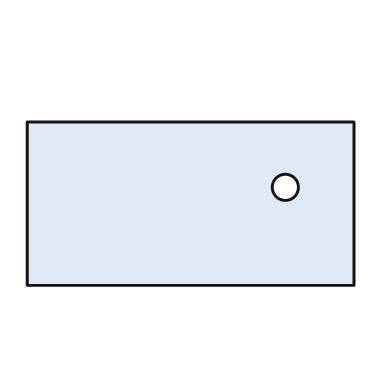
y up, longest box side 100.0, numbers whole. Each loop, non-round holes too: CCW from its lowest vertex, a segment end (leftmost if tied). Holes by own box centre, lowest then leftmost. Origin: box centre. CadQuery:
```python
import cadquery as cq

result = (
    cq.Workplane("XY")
    .moveTo(-50.0, -25.0)
    .lineTo(50.0, -25.0)
    .lineTo(50.0, 25.0)
    .lineTo(-50.0, 25.0)
    .close()
    .moveTo(29.0, 5.0)
    .circle(4.0)
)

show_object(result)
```